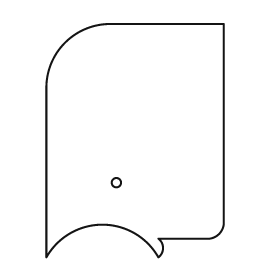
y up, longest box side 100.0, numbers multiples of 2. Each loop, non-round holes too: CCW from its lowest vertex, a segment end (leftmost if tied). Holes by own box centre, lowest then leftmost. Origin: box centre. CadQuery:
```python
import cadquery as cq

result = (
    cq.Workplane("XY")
    .moveTo(-38.0, -50.0)
    .threePointArc((-14.0, -36.0), (10.0, -50.0))
    .threePointArc((12.0, -46.0), (10.0, -42.0))
    .lineTo(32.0, -42.0)
    .threePointArc((36.0, -40.0), (38.0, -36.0))
    .lineTo(38.0, 50.0)
    .lineTo(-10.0, 50.0)
    .threePointArc((-30.0, 42.0), (-38.0, 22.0))
    .close()
    .moveTo(-8.0, -18.0)
    .circle(2.0)
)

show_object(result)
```